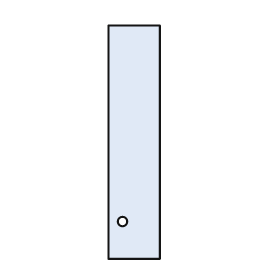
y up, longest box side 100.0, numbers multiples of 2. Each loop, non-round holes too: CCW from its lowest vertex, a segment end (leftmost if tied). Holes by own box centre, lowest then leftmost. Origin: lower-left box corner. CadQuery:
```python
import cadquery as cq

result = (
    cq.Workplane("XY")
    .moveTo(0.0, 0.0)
    .lineTo(22.0, 0.0)
    .lineTo(22.0, 100.0)
    .lineTo(0.0, 100.0)
    .close()
    .moveTo(6.0, 16.0)
    .circle(2.0)
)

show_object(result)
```